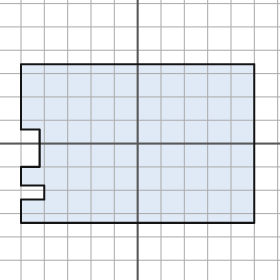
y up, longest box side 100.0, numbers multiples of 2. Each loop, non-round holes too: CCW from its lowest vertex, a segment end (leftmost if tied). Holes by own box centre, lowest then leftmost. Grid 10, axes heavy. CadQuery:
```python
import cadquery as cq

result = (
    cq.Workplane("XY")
    .moveTo(-50.0, -34.0)
    .lineTo(50.0, -34.0)
    .lineTo(50.0, 34.0)
    .lineTo(-50.0, 34.0)
    .lineTo(-50.0, 6.0)
    .lineTo(-42.0, 6.0)
    .lineTo(-42.0, -10.0)
    .lineTo(-50.0, -10.0)
    .lineTo(-50.0, -18.0)
    .lineTo(-40.0, -18.0)
    .lineTo(-40.0, -24.0)
    .lineTo(-50.0, -24.0)
    .close()
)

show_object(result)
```